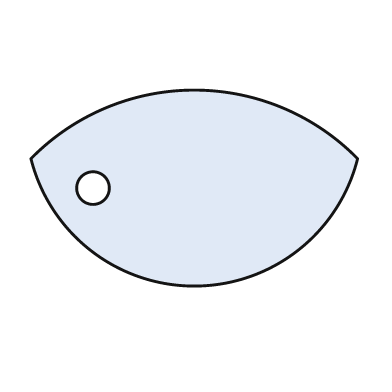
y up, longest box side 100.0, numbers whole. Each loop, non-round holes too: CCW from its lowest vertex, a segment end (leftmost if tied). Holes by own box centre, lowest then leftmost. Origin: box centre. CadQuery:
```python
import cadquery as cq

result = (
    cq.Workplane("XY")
    .moveTo(-50.0, 9.0)
    .threePointArc((0.0, -30.0), (50.0, 9.0))
    .threePointArc((0.0, 30.0), (-50.0, 9.0))
    .close()
    .moveTo(-31.0, 0.0)
    .circle(5.0)
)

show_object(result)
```